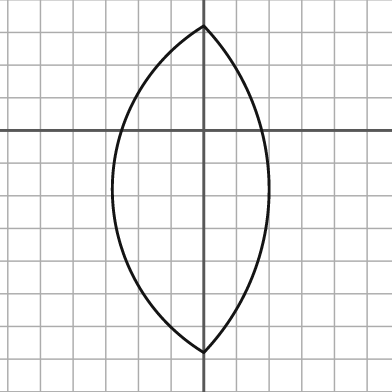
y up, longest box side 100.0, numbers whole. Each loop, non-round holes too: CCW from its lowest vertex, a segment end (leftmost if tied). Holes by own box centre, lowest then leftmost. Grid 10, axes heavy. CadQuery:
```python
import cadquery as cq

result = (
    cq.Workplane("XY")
    .moveTo(0.0, -68.0)
    .threePointArc((20.0, -18.0), (0.0, 32.0))
    .threePointArc((-28.0, -18.0), (0.0, -68.0))
    .close()
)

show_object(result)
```